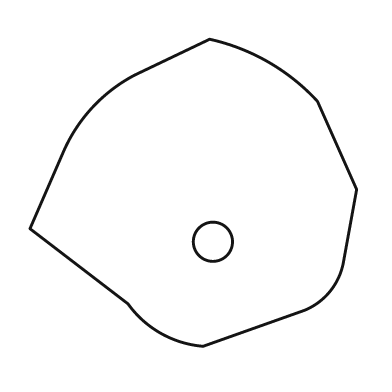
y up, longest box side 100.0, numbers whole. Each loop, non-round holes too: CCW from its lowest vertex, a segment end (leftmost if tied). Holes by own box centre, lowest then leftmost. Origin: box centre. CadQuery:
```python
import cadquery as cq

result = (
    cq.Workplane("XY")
    .moveTo(3.0, -47.0)
    .lineTo(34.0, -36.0)
    .threePointArc((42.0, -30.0), (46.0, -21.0))
    .lineTo(50.0, 1.0)
    .lineTo(38.0, 28.0)
    .threePointArc((23.0, 40.0), (5.0, 47.0))
    .lineTo(-18.0, 36.0)
    .threePointArc((-31.0, 26.0), (-40.0, 12.0))
    .lineTo(-50.0, -11.0)
    .lineTo(-20.0, -34.0)
    .threePointArc((-10.0, -43.0), (3.0, -47.0))
    .close()
    .moveTo(6.0, -15.0)
    .circle(6.0)
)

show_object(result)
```